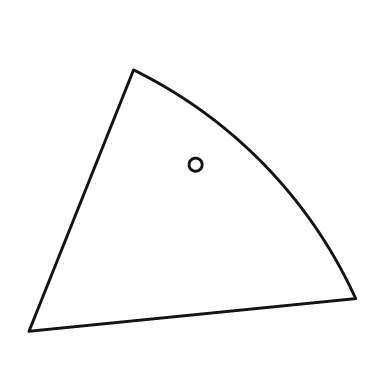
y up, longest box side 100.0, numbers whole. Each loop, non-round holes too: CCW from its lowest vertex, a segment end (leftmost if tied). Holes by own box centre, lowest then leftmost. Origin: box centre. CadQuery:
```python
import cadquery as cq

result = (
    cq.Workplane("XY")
    .moveTo(-50.0, -40.0)
    .lineTo(50.0, -30.0)
    .threePointArc((22.0, 11.0), (-18.0, 40.0))
    .close()
    .moveTo(1.0, 11.0)
    .circle(2.0)
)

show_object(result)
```